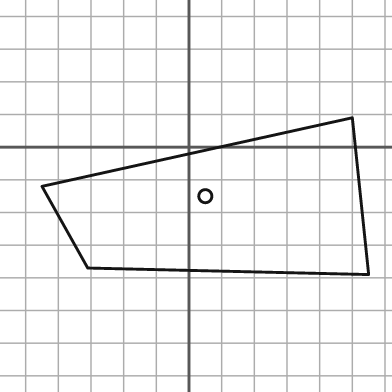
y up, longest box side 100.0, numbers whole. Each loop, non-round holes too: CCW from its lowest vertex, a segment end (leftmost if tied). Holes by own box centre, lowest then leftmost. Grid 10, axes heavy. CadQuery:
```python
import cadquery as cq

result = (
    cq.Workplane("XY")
    .moveTo(55.0, -39.0)
    .lineTo(50.0, 9.0)
    .lineTo(-45.0, -12.0)
    .lineTo(-31.0, -37.0)
    .close()
    .moveTo(5.0, -15.0)
    .circle(2.0)
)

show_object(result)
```